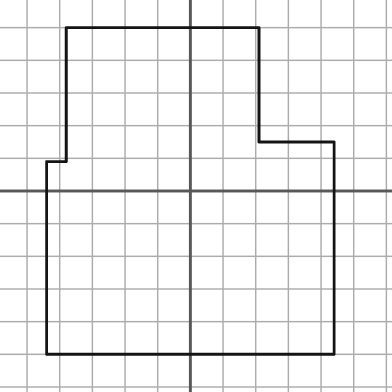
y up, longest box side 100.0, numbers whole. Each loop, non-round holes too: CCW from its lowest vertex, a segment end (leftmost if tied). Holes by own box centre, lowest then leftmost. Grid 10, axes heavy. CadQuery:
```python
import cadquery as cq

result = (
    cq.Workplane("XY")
    .moveTo(-44.0, -50.0)
    .lineTo(44.0, -50.0)
    .lineTo(44.0, 15.0)
    .lineTo(21.0, 15.0)
    .lineTo(21.0, 50.0)
    .lineTo(-38.0, 50.0)
    .lineTo(-38.0, 9.0)
    .lineTo(-44.0, 9.0)
    .close()
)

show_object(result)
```